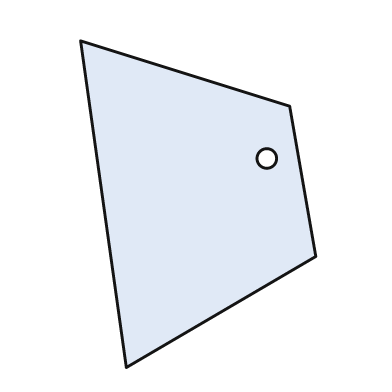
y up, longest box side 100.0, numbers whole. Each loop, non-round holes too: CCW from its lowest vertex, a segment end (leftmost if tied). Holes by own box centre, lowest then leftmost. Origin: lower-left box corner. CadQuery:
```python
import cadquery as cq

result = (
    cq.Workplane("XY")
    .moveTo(14.0, 0.0)
    .lineTo(72.0, 34.0)
    .lineTo(64.0, 80.0)
    .lineTo(0.0, 100.0)
    .close()
    .moveTo(57.0, 64.0)
    .circle(3.0)
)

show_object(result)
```